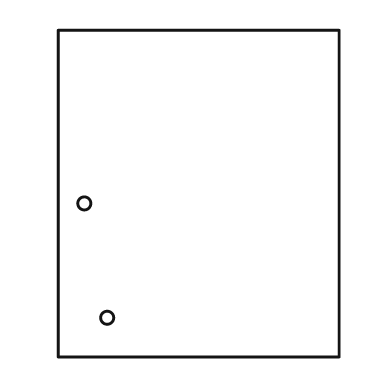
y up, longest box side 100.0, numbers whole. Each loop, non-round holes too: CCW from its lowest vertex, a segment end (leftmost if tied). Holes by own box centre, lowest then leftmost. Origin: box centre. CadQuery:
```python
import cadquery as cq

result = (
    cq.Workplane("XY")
    .moveTo(-43.0, -50.0)
    .lineTo(43.0, -50.0)
    .lineTo(43.0, 50.0)
    .lineTo(-43.0, 50.0)
    .close()
    .moveTo(-28.0, -38.0)
    .circle(2.0)
    .moveTo(-35.0, -3.0)
    .circle(2.0)
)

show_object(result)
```